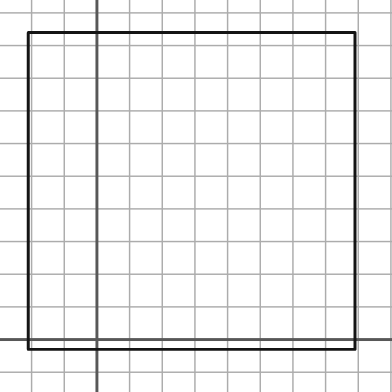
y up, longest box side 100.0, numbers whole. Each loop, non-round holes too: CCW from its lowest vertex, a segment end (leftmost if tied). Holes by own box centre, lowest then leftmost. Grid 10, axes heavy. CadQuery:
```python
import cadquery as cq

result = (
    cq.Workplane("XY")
    .moveTo(-21.0, -3.0)
    .lineTo(79.0, -3.0)
    .lineTo(79.0, 94.0)
    .lineTo(-21.0, 94.0)
    .close()
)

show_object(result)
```